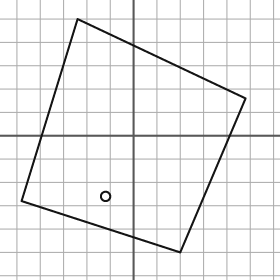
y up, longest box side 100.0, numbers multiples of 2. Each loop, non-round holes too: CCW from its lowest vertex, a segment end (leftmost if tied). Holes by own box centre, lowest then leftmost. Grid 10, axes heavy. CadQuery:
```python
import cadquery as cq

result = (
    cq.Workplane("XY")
    .moveTo(20.0, -50.0)
    .lineTo(48.0, 16.0)
    .lineTo(-24.0, 50.0)
    .lineTo(-48.0, -28.0)
    .close()
    .moveTo(-12.0, -26.0)
    .circle(2.0)
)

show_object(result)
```